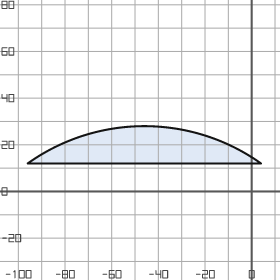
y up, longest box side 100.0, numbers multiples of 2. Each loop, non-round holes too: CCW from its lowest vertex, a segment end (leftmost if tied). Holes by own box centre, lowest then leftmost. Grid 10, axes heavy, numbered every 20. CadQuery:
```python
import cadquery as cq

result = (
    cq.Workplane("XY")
    .moveTo(-96.0, 12.0)
    .lineTo(4.0, 12.0)
    .threePointArc((-46.0, 28.0), (-96.0, 12.0))
    .close()
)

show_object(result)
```